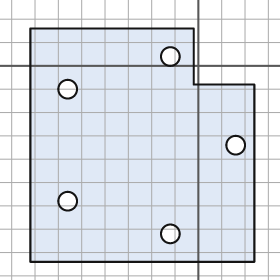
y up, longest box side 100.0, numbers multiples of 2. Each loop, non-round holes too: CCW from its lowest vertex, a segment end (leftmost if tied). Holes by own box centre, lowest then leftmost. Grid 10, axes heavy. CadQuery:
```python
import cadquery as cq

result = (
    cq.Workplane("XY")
    .moveTo(-72.0, -84.0)
    .lineTo(24.0, -84.0)
    .lineTo(24.0, -8.0)
    .lineTo(-2.0, -8.0)
    .lineTo(-2.0, 16.0)
    .lineTo(-72.0, 16.0)
    .close()
    .moveTo(-12.0, -72.0)
    .circle(4.0)
    .moveTo(-56.0, -58.0)
    .circle(4.0)
    .moveTo(16.0, -34.0)
    .circle(4.0)
    .moveTo(-56.0, -10.0)
    .circle(4.0)
    .moveTo(-12.0, 4.0)
    .circle(4.0)
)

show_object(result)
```